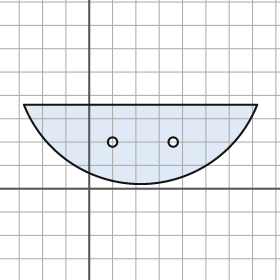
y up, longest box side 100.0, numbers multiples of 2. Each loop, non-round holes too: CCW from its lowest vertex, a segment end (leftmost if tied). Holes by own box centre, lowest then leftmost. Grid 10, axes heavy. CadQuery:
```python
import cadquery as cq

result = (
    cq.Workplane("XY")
    .moveTo(-28.0, 36.0)
    .threePointArc((22.0, 2.0), (72.0, 36.0))
    .close()
    .moveTo(10.0, 20.0)
    .circle(2.0)
    .moveTo(36.0, 20.0)
    .circle(2.0)
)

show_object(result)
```